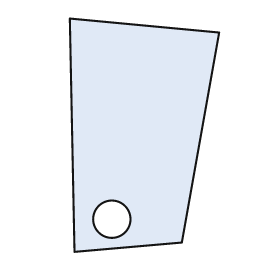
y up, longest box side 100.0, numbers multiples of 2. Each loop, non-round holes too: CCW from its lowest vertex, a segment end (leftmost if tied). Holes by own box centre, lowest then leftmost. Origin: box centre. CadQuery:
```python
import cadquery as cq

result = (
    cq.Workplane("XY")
    .moveTo(-30.0, -50.0)
    .lineTo(16.0, -46.0)
    .lineTo(32.0, 44.0)
    .lineTo(-32.0, 50.0)
    .close()
    .moveTo(-14.0, -36.0)
    .circle(8.0)
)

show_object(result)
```